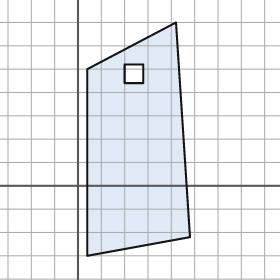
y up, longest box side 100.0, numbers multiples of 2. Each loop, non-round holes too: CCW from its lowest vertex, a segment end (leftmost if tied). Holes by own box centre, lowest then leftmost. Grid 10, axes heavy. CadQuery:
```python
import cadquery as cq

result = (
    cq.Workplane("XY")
    .moveTo(4.0, -30.0)
    .lineTo(48.0, -22.0)
    .lineTo(42.0, 70.0)
    .lineTo(4.0, 50.0)
    .close()
    .moveTo(20.0, 44.0)
    .lineTo(28.0, 44.0)
    .lineTo(28.0, 52.0)
    .lineTo(20.0, 52.0)
    .close()
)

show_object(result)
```